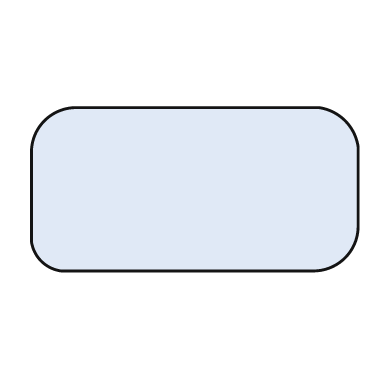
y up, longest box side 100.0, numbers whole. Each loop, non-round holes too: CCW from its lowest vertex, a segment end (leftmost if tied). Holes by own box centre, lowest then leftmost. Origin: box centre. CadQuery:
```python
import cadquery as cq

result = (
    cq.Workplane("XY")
    .moveTo(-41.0, -25.0)
    .lineTo(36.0, -25.0)
    .threePointArc((46.0, -21.0), (50.0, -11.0))
    .lineTo(50.0, 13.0)
    .threePointArc((46.0, 21.0), (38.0, 25.0))
    .lineTo(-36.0, 25.0)
    .threePointArc((-46.0, 21.0), (-50.0, 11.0))
    .lineTo(-50.0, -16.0)
    .threePointArc((-47.0, -22.0), (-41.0, -25.0))
    .close()
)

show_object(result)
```